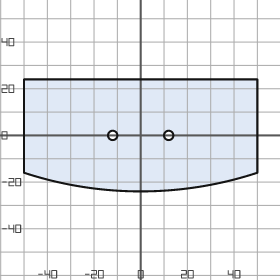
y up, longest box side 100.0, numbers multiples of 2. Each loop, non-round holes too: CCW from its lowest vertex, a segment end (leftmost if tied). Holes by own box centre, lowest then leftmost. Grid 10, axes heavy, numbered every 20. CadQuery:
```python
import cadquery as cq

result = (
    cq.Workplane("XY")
    .moveTo(-50.0, -16.0)
    .threePointArc((0.0, -24.0), (50.0, -16.0))
    .lineTo(50.0, 24.0)
    .lineTo(-50.0, 24.0)
    .close()
    .moveTo(-12.0, 0.0)
    .circle(2.0)
    .moveTo(12.0, 0.0)
    .circle(2.0)
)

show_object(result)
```